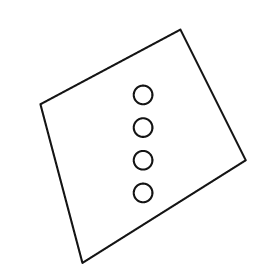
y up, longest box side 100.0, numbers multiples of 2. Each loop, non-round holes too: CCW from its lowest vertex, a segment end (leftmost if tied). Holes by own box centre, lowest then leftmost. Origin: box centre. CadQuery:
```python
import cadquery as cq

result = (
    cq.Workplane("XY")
    .moveTo(-26.0, -50.0)
    .lineTo(44.0, -6.0)
    .lineTo(16.0, 50.0)
    .lineTo(-44.0, 18.0)
    .close()
    .moveTo(0.0, -20.0)
    .circle(4.0)
    .moveTo(0.0, -6.0)
    .circle(4.0)
    .moveTo(0.0, 8.0)
    .circle(4.0)
    .moveTo(0.0, 22.0)
    .circle(4.0)
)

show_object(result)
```